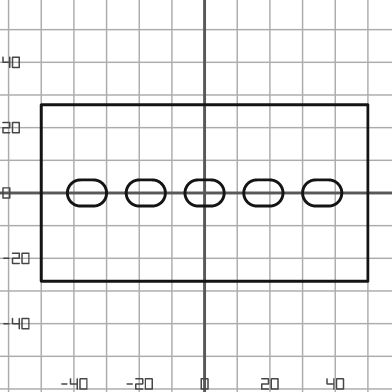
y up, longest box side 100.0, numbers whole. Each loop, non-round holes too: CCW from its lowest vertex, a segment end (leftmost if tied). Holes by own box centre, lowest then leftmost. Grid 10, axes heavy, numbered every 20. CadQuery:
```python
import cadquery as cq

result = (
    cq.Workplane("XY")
    .moveTo(-50.0, -27.0)
    .lineTo(50.0, -27.0)
    .lineTo(50.0, 27.0)
    .lineTo(-50.0, 27.0)
    .close()
    .moveTo(-38.0, -4.0)
    .lineTo(-34.0, -4.0)
    .threePointArc((-30.0, 0.0), (-34.0, 4.0))
    .lineTo(-38.0, 4.0)
    .threePointArc((-42.0, 0.0), (-38.0, -4.0))
    .close()
    .moveTo(-20.0, -4.0)
    .lineTo(-16.0, -4.0)
    .threePointArc((-12.0, 0.0), (-16.0, 4.0))
    .lineTo(-20.0, 4.0)
    .threePointArc((-24.0, 0.0), (-20.0, -4.0))
    .close()
    .moveTo(-2.0, -4.0)
    .lineTo(2.0, -4.0)
    .threePointArc((6.0, 0.0), (2.0, 4.0))
    .lineTo(-2.0, 4.0)
    .threePointArc((-6.0, 0.0), (-2.0, -4.0))
    .close()
    .moveTo(16.0, -4.0)
    .lineTo(20.0, -4.0)
    .threePointArc((24.0, 0.0), (20.0, 4.0))
    .lineTo(16.0, 4.0)
    .threePointArc((12.0, 0.0), (16.0, -4.0))
    .close()
    .moveTo(34.0, -4.0)
    .lineTo(38.0, -4.0)
    .threePointArc((42.0, 0.0), (38.0, 4.0))
    .lineTo(34.0, 4.0)
    .threePointArc((30.0, 0.0), (34.0, -4.0))
    .close()
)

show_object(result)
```